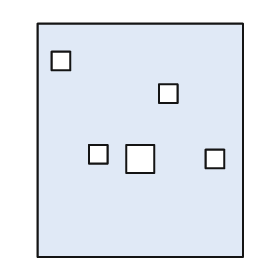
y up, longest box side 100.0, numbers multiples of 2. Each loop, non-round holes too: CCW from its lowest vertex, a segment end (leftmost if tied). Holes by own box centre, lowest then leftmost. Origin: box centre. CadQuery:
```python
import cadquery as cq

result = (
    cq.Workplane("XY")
    .moveTo(-44.0, -50.0)
    .lineTo(44.0, -50.0)
    .lineTo(44.0, 50.0)
    .lineTo(-44.0, 50.0)
    .close()
    .moveTo(-6.0, -14.0)
    .lineTo(6.0, -14.0)
    .lineTo(6.0, -2.0)
    .lineTo(-6.0, -2.0)
    .close()
    .moveTo(28.0, -12.0)
    .lineTo(36.0, -12.0)
    .lineTo(36.0, -4.0)
    .lineTo(28.0, -4.0)
    .close()
    .moveTo(-22.0, -10.0)
    .lineTo(-14.0, -10.0)
    .lineTo(-14.0, -2.0)
    .lineTo(-22.0, -2.0)
    .close()
    .moveTo(8.0, 16.0)
    .lineTo(16.0, 16.0)
    .lineTo(16.0, 24.0)
    .lineTo(8.0, 24.0)
    .close()
    .moveTo(-38.0, 30.0)
    .lineTo(-30.0, 30.0)
    .lineTo(-30.0, 38.0)
    .lineTo(-38.0, 38.0)
    .close()
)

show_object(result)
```